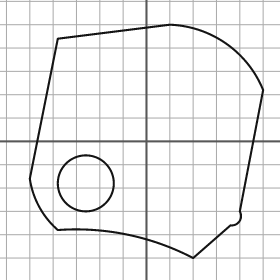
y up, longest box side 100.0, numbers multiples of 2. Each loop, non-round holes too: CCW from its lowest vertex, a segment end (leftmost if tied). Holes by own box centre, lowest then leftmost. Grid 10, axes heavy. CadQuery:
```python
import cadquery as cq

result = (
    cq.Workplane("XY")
    .moveTo(20.0, -50.0)
    .lineTo(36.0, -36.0)
    .threePointArc((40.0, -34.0), (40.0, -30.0))
    .lineTo(50.0, 22.0)
    .threePointArc((34.0, 42.0), (10.0, 50.0))
    .lineTo(-38.0, 44.0)
    .lineTo(-50.0, -16.0)
    .threePointArc((-46.0, -28.0), (-38.0, -38.0))
    .threePointArc((-8.0, -40.0), (20.0, -50.0))
    .close()
    .moveTo(-26.0, -18.0)
    .circle(12.0)
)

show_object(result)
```